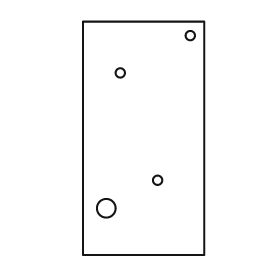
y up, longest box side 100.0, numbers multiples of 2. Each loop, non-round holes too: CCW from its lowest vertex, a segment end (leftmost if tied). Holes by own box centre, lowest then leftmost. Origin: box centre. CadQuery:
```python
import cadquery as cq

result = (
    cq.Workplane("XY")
    .moveTo(-26.0, -50.0)
    .lineTo(26.0, -50.0)
    .lineTo(26.0, 50.0)
    .lineTo(-26.0, 50.0)
    .close()
    .moveTo(-16.0, -30.0)
    .circle(4.0)
    .moveTo(6.0, -18.0)
    .circle(2.0)
    .moveTo(-10.0, 28.0)
    .circle(2.0)
    .moveTo(20.0, 44.0)
    .circle(2.0)
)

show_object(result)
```